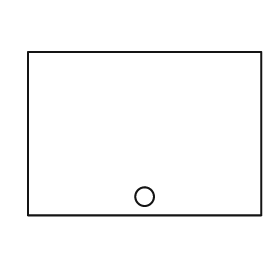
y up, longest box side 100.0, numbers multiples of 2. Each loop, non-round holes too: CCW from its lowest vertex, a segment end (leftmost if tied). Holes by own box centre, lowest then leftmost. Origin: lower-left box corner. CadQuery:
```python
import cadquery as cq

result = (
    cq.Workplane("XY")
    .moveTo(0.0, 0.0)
    .lineTo(100.0, 0.0)
    .lineTo(100.0, 70.0)
    .lineTo(0.0, 70.0)
    .close()
    .moveTo(50.0, 8.0)
    .circle(4.0)
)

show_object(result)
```